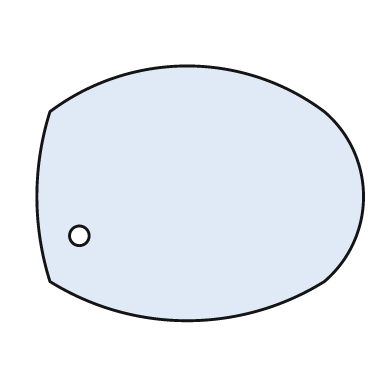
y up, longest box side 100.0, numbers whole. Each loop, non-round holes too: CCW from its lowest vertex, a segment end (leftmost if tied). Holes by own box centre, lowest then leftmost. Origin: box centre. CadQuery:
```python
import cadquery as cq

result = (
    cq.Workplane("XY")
    .moveTo(-46.0, -27.0)
    .threePointArc((-4.0, -39.0), (38.0, -27.0))
    .threePointArc((50.0, -1.0), (38.0, 25.0))
    .threePointArc((-4.0, 39.0), (-46.0, 25.0))
    .threePointArc((-50.0, -1.0), (-46.0, -27.0))
    .close()
    .moveTo(-37.0, -13.0)
    .circle(3.0)
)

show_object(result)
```